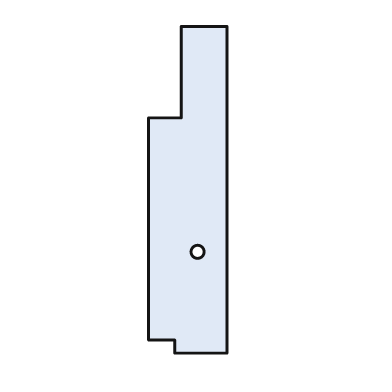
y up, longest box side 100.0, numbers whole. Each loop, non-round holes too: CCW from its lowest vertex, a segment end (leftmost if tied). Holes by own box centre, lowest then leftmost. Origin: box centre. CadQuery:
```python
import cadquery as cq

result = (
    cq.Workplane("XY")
    .moveTo(-4.0, -50.0)
    .lineTo(12.0, -50.0)
    .lineTo(12.0, 50.0)
    .lineTo(-2.0, 50.0)
    .lineTo(-2.0, 22.0)
    .lineTo(-12.0, 22.0)
    .lineTo(-12.0, -46.0)
    .lineTo(-4.0, -46.0)
    .close()
    .moveTo(3.0, -19.0)
    .circle(2.0)
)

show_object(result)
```